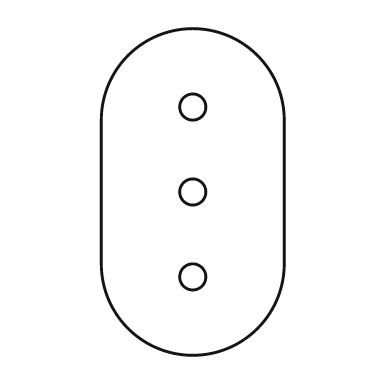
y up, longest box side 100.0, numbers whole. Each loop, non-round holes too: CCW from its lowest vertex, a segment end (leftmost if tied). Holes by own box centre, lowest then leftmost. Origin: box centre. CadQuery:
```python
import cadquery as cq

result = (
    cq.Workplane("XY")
    .moveTo(-28.0, -22.0)
    .threePointArc((0.0, -50.0), (28.0, -22.0))
    .lineTo(28.0, 22.0)
    .threePointArc((0.0, 50.0), (-28.0, 22.0))
    .close()
    .moveTo(0.0, -26.0)
    .circle(4.0)
    .moveTo(0.0, 0.0)
    .circle(4.0)
    .moveTo(0.0, 26.0)
    .circle(4.0)
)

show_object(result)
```